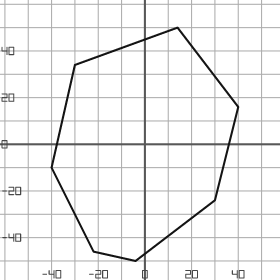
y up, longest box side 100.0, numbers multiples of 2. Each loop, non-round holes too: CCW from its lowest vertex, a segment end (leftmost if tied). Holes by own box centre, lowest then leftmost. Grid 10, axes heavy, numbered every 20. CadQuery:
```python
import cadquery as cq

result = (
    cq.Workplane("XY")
    .moveTo(-4.0, -50.0)
    .lineTo(30.0, -24.0)
    .lineTo(40.0, 16.0)
    .lineTo(14.0, 50.0)
    .lineTo(-30.0, 34.0)
    .lineTo(-40.0, -10.0)
    .lineTo(-22.0, -46.0)
    .close()
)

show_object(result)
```